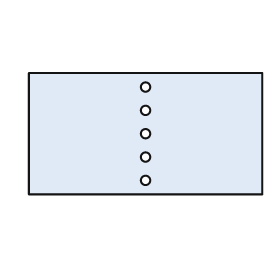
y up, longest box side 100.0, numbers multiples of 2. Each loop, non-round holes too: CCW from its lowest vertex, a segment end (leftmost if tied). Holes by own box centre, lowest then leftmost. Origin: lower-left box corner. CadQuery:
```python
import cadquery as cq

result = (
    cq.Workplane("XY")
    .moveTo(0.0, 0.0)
    .lineTo(100.0, 0.0)
    .lineTo(100.0, 52.0)
    .lineTo(0.0, 52.0)
    .close()
    .moveTo(50.0, 6.0)
    .circle(2.0)
    .moveTo(50.0, 16.0)
    .circle(2.0)
    .moveTo(50.0, 26.0)
    .circle(2.0)
    .moveTo(50.0, 36.0)
    .circle(2.0)
    .moveTo(50.0, 46.0)
    .circle(2.0)
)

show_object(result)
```